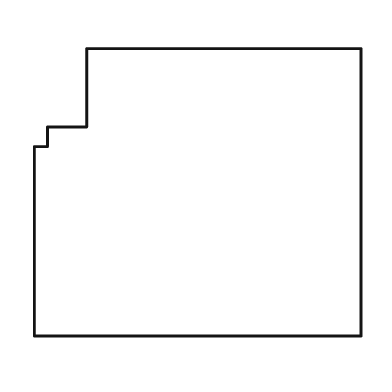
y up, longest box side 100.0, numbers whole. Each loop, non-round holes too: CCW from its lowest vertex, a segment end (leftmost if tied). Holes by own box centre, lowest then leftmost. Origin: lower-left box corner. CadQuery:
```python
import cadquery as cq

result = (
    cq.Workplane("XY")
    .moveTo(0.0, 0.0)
    .lineTo(100.0, 0.0)
    .lineTo(100.0, 88.0)
    .lineTo(16.0, 88.0)
    .lineTo(16.0, 64.0)
    .lineTo(4.0, 64.0)
    .lineTo(4.0, 58.0)
    .lineTo(0.0, 58.0)
    .close()
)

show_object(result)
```